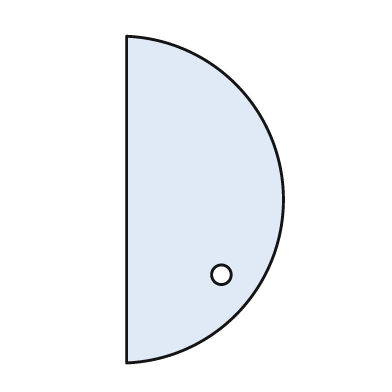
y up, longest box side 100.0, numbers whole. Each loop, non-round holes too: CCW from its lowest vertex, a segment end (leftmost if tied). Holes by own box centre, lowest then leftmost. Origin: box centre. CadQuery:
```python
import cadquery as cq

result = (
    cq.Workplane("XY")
    .moveTo(-24.0, -50.0)
    .threePointArc((24.0, 0.0), (-24.0, 50.0))
    .close()
    .moveTo(5.0, -23.0)
    .circle(3.0)
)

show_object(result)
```